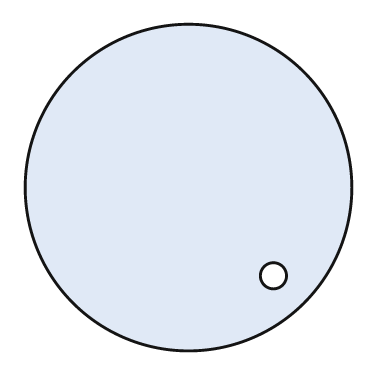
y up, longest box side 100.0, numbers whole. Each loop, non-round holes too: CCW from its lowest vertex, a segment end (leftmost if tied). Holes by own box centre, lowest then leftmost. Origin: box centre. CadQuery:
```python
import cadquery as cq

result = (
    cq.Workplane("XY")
    .moveTo(0.0, 0.0)
    .circle(50.0)
    .moveTo(26.0, -27.0)
    .circle(4.0)
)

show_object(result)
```